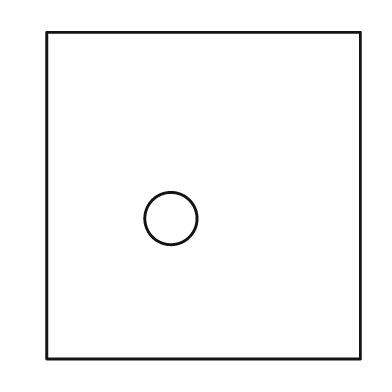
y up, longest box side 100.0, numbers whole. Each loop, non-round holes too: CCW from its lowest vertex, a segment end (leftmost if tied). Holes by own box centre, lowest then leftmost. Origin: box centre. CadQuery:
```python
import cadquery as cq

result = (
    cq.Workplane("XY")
    .moveTo(-48.0, -50.0)
    .lineTo(48.0, -50.0)
    .lineTo(48.0, 50.0)
    .lineTo(-48.0, 50.0)
    .close()
    .moveTo(-10.0, -7.0)
    .circle(8.0)
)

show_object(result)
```